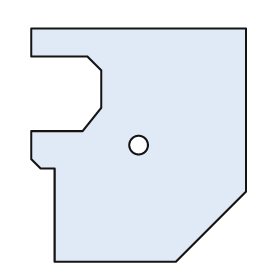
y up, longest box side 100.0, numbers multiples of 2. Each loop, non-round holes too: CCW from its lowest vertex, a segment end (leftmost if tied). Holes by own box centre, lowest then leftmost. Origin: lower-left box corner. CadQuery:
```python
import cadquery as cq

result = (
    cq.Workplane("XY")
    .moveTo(10.0, 0.0)
    .lineTo(62.0, 0.0)
    .lineTo(92.0, 30.0)
    .lineTo(92.0, 100.0)
    .lineTo(0.0, 100.0)
    .lineTo(0.0, 88.0)
    .lineTo(24.0, 88.0)
    .lineTo(30.0, 82.0)
    .lineTo(30.0, 66.0)
    .lineTo(22.0, 56.0)
    .lineTo(0.0, 56.0)
    .lineTo(0.0, 44.0)
    .lineTo(4.0, 40.0)
    .lineTo(10.0, 40.0)
    .close()
    .moveTo(46.0, 50.0)
    .circle(4.0)
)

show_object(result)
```